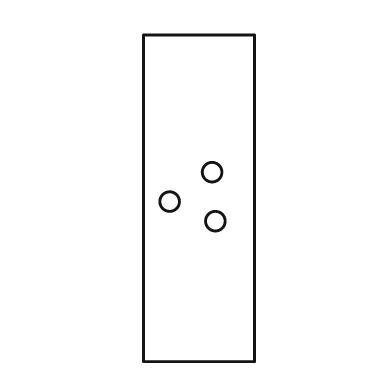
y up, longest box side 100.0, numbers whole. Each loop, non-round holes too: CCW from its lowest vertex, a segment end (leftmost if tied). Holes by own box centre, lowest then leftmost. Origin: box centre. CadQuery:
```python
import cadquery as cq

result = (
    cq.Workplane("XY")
    .moveTo(-17.0, -50.0)
    .lineTo(17.0, -50.0)
    .lineTo(17.0, 50.0)
    .lineTo(-17.0, 50.0)
    .close()
    .moveTo(5.0, -7.0)
    .circle(3.0)
    .moveTo(-9.0, -1.0)
    .circle(3.0)
    .moveTo(4.0, 8.0)
    .circle(3.0)
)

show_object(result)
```